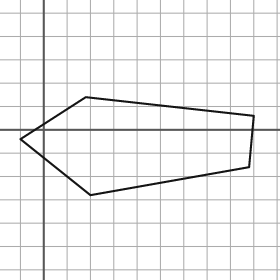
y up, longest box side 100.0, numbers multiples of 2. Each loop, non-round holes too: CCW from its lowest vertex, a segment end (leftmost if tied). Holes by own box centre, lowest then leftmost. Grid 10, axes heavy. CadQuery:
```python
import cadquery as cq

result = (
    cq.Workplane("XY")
    .moveTo(20.0, -28.0)
    .lineTo(88.0, -16.0)
    .lineTo(90.0, 6.0)
    .lineTo(18.0, 14.0)
    .lineTo(-10.0, -4.0)
    .close()
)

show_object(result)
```